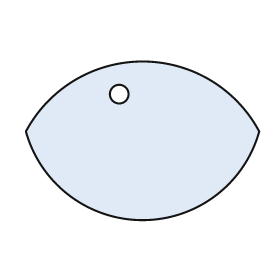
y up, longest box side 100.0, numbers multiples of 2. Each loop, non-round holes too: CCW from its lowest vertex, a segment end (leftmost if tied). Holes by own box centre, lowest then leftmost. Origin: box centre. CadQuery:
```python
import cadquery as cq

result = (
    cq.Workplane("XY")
    .moveTo(-50.0, 4.0)
    .threePointArc((0.0, -34.0), (50.0, 4.0))
    .threePointArc((0.0, 34.0), (-50.0, 4.0))
    .close()
    .moveTo(-10.0, 20.0)
    .circle(4.0)
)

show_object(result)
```